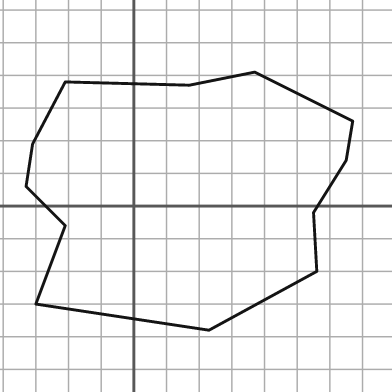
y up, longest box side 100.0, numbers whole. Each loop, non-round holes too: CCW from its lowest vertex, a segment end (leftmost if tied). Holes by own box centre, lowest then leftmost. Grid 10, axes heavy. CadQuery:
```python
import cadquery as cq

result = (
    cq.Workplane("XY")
    .moveTo(23.0, -38.0)
    .lineTo(56.0, -20.0)
    .lineTo(55.0, -2.0)
    .lineTo(65.0, 14.0)
    .lineTo(67.0, 26.0)
    .lineTo(37.0, 41.0)
    .lineTo(17.0, 37.0)
    .lineTo(-21.0, 38.0)
    .lineTo(-31.0, 19.0)
    .lineTo(-33.0, 6.0)
    .lineTo(-21.0, -6.0)
    .lineTo(-30.0, -30.0)
    .close()
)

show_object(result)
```